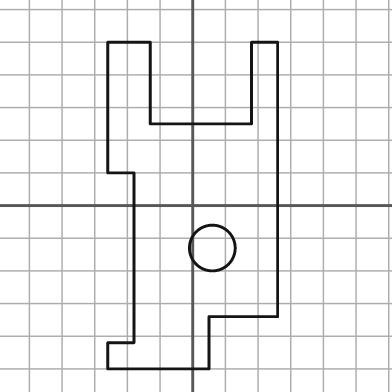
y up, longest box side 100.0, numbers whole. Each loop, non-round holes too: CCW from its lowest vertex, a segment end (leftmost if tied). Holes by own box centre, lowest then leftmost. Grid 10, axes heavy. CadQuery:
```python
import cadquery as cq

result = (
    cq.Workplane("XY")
    .moveTo(-26.0, -50.0)
    .lineTo(5.0, -50.0)
    .lineTo(5.0, -34.0)
    .lineTo(26.0, -34.0)
    .lineTo(26.0, 50.0)
    .lineTo(18.0, 50.0)
    .lineTo(18.0, 25.0)
    .lineTo(-13.0, 25.0)
    .lineTo(-13.0, 50.0)
    .lineTo(-26.0, 50.0)
    .lineTo(-26.0, 10.0)
    .lineTo(-18.0, 10.0)
    .lineTo(-18.0, -42.0)
    .lineTo(-26.0, -42.0)
    .close()
    .moveTo(6.0, -13.0)
    .circle(7.0)
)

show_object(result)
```